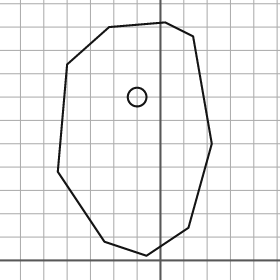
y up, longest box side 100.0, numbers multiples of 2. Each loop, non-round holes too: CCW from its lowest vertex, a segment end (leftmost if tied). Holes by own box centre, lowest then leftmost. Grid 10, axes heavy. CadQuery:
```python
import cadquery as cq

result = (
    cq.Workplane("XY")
    .moveTo(-6.0, 2.0)
    .lineTo(12.0, 14.0)
    .lineTo(22.0, 50.0)
    .lineTo(14.0, 96.0)
    .lineTo(2.0, 102.0)
    .lineTo(-22.0, 100.0)
    .lineTo(-40.0, 84.0)
    .lineTo(-44.0, 38.0)
    .lineTo(-24.0, 8.0)
    .close()
    .moveTo(-10.0, 70.0)
    .circle(4.0)
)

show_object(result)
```